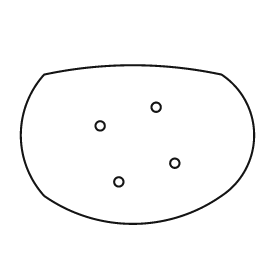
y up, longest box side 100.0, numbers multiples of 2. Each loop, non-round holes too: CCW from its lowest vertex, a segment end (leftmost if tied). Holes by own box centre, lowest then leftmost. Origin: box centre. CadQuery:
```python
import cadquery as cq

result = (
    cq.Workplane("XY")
    .moveTo(-40.0, -22.0)
    .threePointArc((-2.0, -34.0), (36.0, -22.0))
    .threePointArc((50.0, 4.0), (36.0, 30.0))
    .threePointArc((-2.0, 34.0), (-40.0, 30.0))
    .threePointArc((-50.0, 4.0), (-40.0, -22.0))
    .close()
    .moveTo(-8.0, -16.0)
    .circle(2.0)
    .moveTo(16.0, -8.0)
    .circle(2.0)
    .moveTo(-16.0, 8.0)
    .circle(2.0)
    .moveTo(8.0, 16.0)
    .circle(2.0)
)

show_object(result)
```